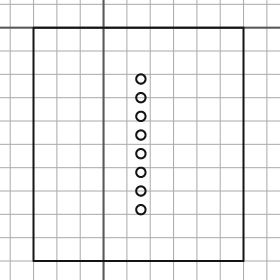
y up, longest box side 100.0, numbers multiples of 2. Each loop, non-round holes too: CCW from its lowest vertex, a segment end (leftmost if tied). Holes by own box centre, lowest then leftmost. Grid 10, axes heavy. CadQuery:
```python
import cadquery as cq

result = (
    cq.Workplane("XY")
    .moveTo(-30.0, -100.0)
    .lineTo(60.0, -100.0)
    .lineTo(60.0, 0.0)
    .lineTo(-30.0, 0.0)
    .close()
    .moveTo(16.0, -78.0)
    .circle(2.0)
    .moveTo(16.0, -70.0)
    .circle(2.0)
    .moveTo(16.0, -62.0)
    .circle(2.0)
    .moveTo(16.0, -54.0)
    .circle(2.0)
    .moveTo(16.0, -46.0)
    .circle(2.0)
    .moveTo(16.0, -38.0)
    .circle(2.0)
    .moveTo(16.0, -30.0)
    .circle(2.0)
    .moveTo(16.0, -22.0)
    .circle(2.0)
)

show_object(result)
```